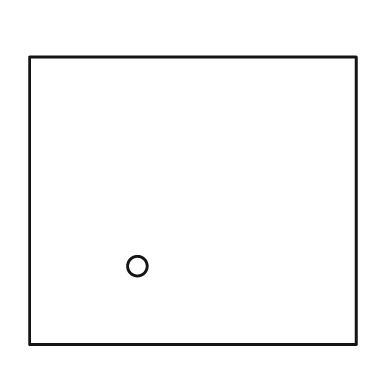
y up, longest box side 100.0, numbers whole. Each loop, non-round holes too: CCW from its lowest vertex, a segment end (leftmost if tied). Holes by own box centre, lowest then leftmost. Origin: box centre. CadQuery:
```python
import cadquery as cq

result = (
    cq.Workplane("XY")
    .moveTo(-50.0, -44.0)
    .lineTo(50.0, -44.0)
    .lineTo(50.0, 44.0)
    .lineTo(-50.0, 44.0)
    .close()
    .moveTo(-17.0, -20.0)
    .circle(3.0)
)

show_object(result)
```